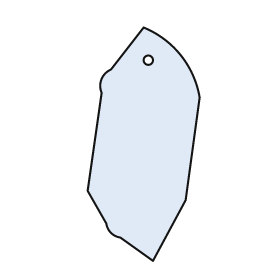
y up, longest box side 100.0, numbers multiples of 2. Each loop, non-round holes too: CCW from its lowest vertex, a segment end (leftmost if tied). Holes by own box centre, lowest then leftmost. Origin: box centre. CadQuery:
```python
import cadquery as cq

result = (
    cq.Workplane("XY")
    .moveTo(4.0, -50.0)
    .lineTo(18.0, -24.0)
    .lineTo(24.0, 20.0)
    .threePointArc((16.0, 38.0), (0.0, 50.0))
    .lineTo(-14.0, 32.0)
    .threePointArc((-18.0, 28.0), (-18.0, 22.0))
    .lineTo(-24.0, -20.0)
    .lineTo(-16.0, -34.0)
    .threePointArc((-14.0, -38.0), (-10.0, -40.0))
    .close()
    .moveTo(2.0, 36.0)
    .circle(2.0)
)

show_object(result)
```